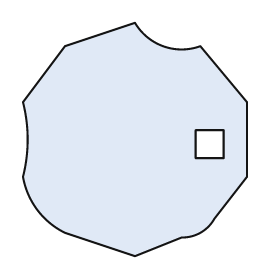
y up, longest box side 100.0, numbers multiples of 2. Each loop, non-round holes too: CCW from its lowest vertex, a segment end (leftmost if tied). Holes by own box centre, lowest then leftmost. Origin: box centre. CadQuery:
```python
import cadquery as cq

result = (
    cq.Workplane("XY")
    .moveTo(0.0, -50.0)
    .lineTo(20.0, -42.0)
    .threePointArc((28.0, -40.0), (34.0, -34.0))
    .lineTo(48.0, -16.0)
    .lineTo(48.0, 16.0)
    .lineTo(28.0, 40.0)
    .threePointArc((12.0, 40.0), (0.0, 50.0))
    .lineTo(-30.0, 40.0)
    .lineTo(-48.0, 16.0)
    .threePointArc((-46.0, 0.0), (-48.0, -16.0))
    .threePointArc((-42.0, -30.0), (-30.0, -40.0))
    .close()
    .moveTo(26.0, -8.0)
    .lineTo(38.0, -8.0)
    .lineTo(38.0, 4.0)
    .lineTo(26.0, 4.0)
    .close()
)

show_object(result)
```